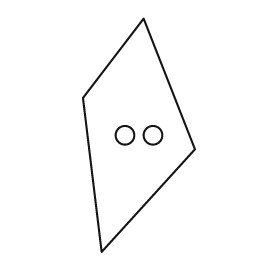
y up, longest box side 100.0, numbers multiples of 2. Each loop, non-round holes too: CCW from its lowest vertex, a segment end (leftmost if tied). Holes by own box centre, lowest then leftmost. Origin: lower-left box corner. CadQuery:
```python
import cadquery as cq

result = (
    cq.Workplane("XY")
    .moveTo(8.0, 0.0)
    .lineTo(48.0, 44.0)
    .lineTo(26.0, 100.0)
    .lineTo(0.0, 66.0)
    .close()
    .moveTo(18.0, 50.0)
    .circle(4.0)
    .moveTo(30.0, 50.0)
    .circle(4.0)
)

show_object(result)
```